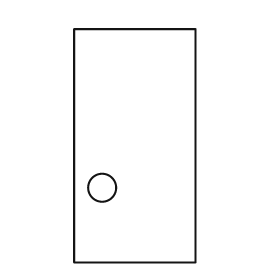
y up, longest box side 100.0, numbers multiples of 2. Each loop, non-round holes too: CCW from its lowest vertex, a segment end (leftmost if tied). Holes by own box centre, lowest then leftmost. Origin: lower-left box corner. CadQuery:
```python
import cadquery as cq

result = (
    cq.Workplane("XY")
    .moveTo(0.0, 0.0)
    .lineTo(52.0, 0.0)
    .lineTo(52.0, 100.0)
    .lineTo(0.0, 100.0)
    .close()
    .moveTo(12.0, 32.0)
    .circle(6.0)
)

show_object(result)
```